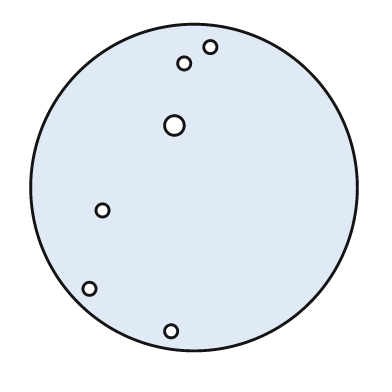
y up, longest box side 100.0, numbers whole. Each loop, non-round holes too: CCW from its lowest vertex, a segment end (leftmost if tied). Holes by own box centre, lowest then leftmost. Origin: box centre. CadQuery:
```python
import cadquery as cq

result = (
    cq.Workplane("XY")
    .moveTo(0.0, 0.0)
    .circle(50.0)
    .moveTo(-7.0, -44.0)
    .circle(2.0)
    .moveTo(-32.0, -31.0)
    .circle(2.0)
    .moveTo(-28.0, -7.0)
    .circle(2.0)
    .moveTo(-6.0, 19.0)
    .circle(3.0)
    .moveTo(-3.0, 38.0)
    .circle(2.0)
    .moveTo(5.0, 43.0)
    .circle(2.0)
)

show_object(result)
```